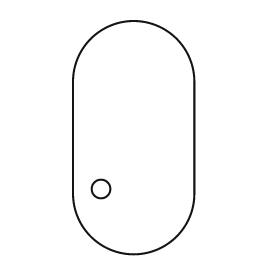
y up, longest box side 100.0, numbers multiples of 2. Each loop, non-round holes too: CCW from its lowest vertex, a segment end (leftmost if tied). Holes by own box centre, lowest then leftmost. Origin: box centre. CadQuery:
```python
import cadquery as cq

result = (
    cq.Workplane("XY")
    .moveTo(-26.0, -24.0)
    .threePointArc((0.0, -50.0), (26.0, -24.0))
    .lineTo(26.0, 24.0)
    .threePointArc((0.0, 50.0), (-26.0, 24.0))
    .close()
    .moveTo(-14.0, -22.0)
    .circle(4.0)
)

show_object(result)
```